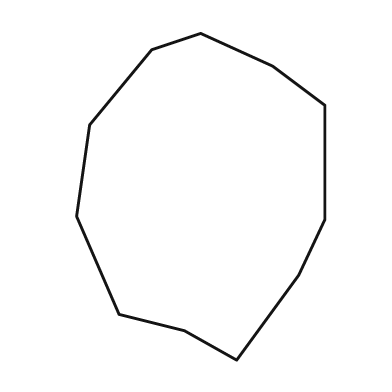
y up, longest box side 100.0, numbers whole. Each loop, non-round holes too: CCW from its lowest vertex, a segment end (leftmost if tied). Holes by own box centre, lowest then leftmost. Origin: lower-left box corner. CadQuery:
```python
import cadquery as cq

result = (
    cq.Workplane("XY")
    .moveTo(49.0, 0.0)
    .lineTo(68.0, 26.0)
    .lineTo(76.0, 43.0)
    .lineTo(76.0, 78.0)
    .lineTo(60.0, 90.0)
    .lineTo(38.0, 100.0)
    .lineTo(23.0, 95.0)
    .lineTo(4.0, 72.0)
    .lineTo(0.0, 44.0)
    .lineTo(13.0, 14.0)
    .lineTo(33.0, 9.0)
    .close()
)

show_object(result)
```